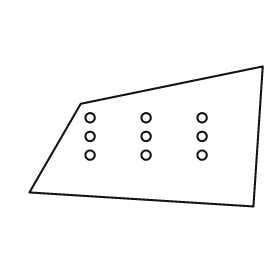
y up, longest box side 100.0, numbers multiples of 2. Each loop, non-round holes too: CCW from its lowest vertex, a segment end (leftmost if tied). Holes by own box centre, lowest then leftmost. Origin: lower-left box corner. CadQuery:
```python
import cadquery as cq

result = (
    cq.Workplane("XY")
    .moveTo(96.0, 0.0)
    .lineTo(100.0, 60.0)
    .lineTo(22.0, 44.0)
    .lineTo(0.0, 6.0)
    .close()
    .moveTo(26.0, 22.0)
    .circle(2.0)
    .moveTo(50.0, 22.0)
    .circle(2.0)
    .moveTo(74.0, 22.0)
    .circle(2.0)
    .moveTo(26.0, 30.0)
    .circle(2.0)
    .moveTo(50.0, 30.0)
    .circle(2.0)
    .moveTo(74.0, 30.0)
    .circle(2.0)
    .moveTo(26.0, 38.0)
    .circle(2.0)
    .moveTo(50.0, 38.0)
    .circle(2.0)
    .moveTo(74.0, 38.0)
    .circle(2.0)
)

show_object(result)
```